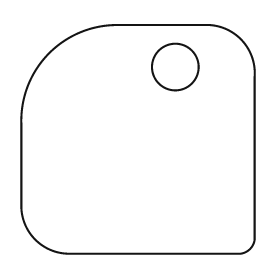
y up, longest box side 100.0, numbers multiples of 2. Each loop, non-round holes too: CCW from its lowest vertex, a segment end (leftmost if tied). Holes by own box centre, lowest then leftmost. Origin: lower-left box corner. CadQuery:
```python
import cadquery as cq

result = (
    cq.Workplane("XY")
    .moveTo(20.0, 0.0)
    .lineTo(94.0, 0.0)
    .threePointArc((98.0, 2.0), (100.0, 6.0))
    .lineTo(100.0, 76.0)
    .threePointArc((94.0, 92.0), (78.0, 98.0))
    .lineTo(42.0, 98.0)
    .threePointArc((12.0, 86.0), (0.0, 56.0))
    .lineTo(0.0, 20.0)
    .threePointArc((6.0, 6.0), (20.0, 0.0))
    .close()
    .moveTo(66.0, 80.0)
    .circle(10.0)
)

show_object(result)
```